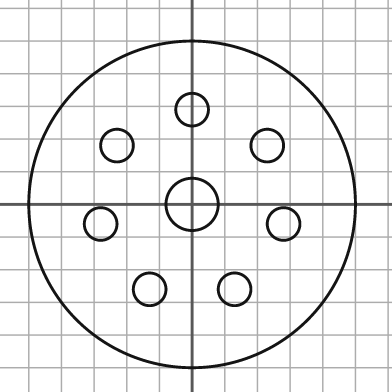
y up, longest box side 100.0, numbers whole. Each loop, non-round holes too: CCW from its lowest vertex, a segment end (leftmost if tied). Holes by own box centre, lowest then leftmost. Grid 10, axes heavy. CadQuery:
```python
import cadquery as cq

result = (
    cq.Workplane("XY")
    .moveTo(0.0, 0.0)
    .circle(50.0)
    .moveTo(-13.0, -26.0)
    .circle(5.0)
    .moveTo(13.0, -26.0)
    .circle(5.0)
    .moveTo(-28.0, -6.0)
    .circle(5.0)
    .moveTo(28.0, -6.0)
    .circle(5.0)
    .moveTo(0.0, 0.0)
    .circle(8.0)
    .moveTo(-23.0, 18.0)
    .circle(5.0)
    .moveTo(23.0, 18.0)
    .circle(5.0)
    .moveTo(0.0, 29.0)
    .circle(5.0)
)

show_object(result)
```